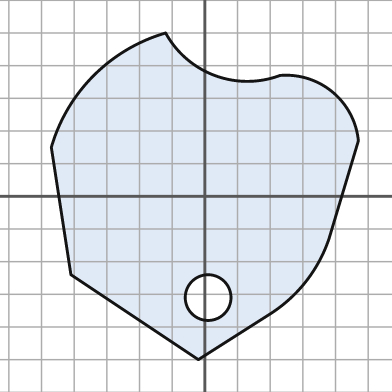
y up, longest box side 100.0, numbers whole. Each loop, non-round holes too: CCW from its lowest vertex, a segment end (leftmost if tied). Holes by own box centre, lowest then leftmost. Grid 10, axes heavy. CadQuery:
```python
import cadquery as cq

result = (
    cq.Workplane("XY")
    .moveTo(-2.0, -50.0)
    .lineTo(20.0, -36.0)
    .threePointArc((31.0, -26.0), (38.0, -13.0))
    .lineTo(47.0, 17.0)
    .threePointArc((39.0, 32.0), (23.0, 37.0))
    .threePointArc((3.0, 37.0), (-12.0, 50.0))
    .threePointArc((-34.0, 37.0), (-47.0, 15.0))
    .lineTo(-41.0, -24.0)
    .close()
    .moveTo(1.0, -31.0)
    .circle(7.0)
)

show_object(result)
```